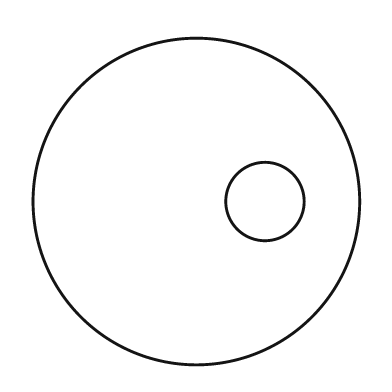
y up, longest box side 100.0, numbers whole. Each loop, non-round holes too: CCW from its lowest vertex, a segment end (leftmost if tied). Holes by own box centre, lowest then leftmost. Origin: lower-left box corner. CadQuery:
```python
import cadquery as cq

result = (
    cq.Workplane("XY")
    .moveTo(50.0, 50.0)
    .circle(50.0)
    .moveTo(71.0, 50.0)
    .circle(12.0)
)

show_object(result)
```